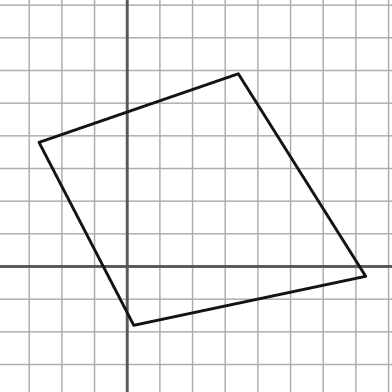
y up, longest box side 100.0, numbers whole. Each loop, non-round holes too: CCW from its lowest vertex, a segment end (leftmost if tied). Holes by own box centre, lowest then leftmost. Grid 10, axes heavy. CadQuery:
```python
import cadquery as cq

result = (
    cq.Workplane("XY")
    .moveTo(2.0, -18.0)
    .lineTo(73.0, -3.0)
    .lineTo(34.0, 59.0)
    .lineTo(-27.0, 38.0)
    .close()
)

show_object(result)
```